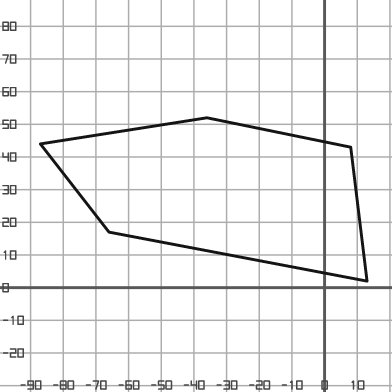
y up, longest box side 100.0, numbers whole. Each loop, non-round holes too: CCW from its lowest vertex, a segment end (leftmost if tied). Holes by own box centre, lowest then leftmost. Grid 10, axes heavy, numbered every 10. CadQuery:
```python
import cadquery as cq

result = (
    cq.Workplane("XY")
    .moveTo(13.0, 2.0)
    .lineTo(8.0, 43.0)
    .lineTo(-36.0, 52.0)
    .lineTo(-87.0, 44.0)
    .lineTo(-66.0, 17.0)
    .close()
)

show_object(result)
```